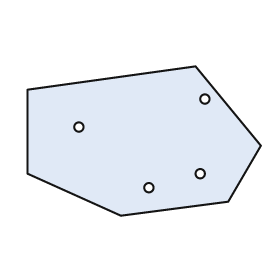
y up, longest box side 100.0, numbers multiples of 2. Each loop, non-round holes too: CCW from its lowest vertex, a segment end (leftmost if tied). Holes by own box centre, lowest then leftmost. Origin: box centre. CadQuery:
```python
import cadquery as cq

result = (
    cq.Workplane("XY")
    .moveTo(-10.0, -32.0)
    .lineTo(36.0, -26.0)
    .lineTo(50.0, -2.0)
    .lineTo(22.0, 32.0)
    .lineTo(-50.0, 22.0)
    .lineTo(-50.0, -14.0)
    .close()
    .moveTo(2.0, -20.0)
    .circle(2.0)
    .moveTo(24.0, -14.0)
    .circle(2.0)
    .moveTo(-28.0, 6.0)
    .circle(2.0)
    .moveTo(26.0, 18.0)
    .circle(2.0)
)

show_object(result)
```